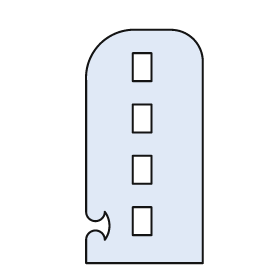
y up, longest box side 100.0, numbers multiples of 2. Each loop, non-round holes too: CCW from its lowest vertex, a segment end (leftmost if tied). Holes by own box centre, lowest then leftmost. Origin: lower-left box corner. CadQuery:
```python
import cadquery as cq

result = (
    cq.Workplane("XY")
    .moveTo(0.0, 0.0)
    .lineTo(50.0, 0.0)
    .lineTo(50.0, 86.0)
    .threePointArc((46.0, 96.0), (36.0, 100.0))
    .lineTo(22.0, 100.0)
    .threePointArc((6.0, 94.0), (0.0, 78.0))
    .lineTo(0.0, 22.0)
    .threePointArc((4.0, 18.0), (8.0, 22.0))
    .threePointArc((10.0, 16.0), (8.0, 10.0))
    .threePointArc((4.0, 14.0), (0.0, 10.0))
    .close()
    .moveTo(20.0, 12.0)
    .lineTo(28.0, 12.0)
    .lineTo(28.0, 24.0)
    .lineTo(20.0, 24.0)
    .close()
    .moveTo(20.0, 34.0)
    .lineTo(28.0, 34.0)
    .lineTo(28.0, 46.0)
    .lineTo(20.0, 46.0)
    .close()
    .moveTo(20.0, 56.0)
    .lineTo(28.0, 56.0)
    .lineTo(28.0, 68.0)
    .lineTo(20.0, 68.0)
    .close()
    .moveTo(20.0, 78.0)
    .lineTo(28.0, 78.0)
    .lineTo(28.0, 90.0)
    .lineTo(20.0, 90.0)
    .close()
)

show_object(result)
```